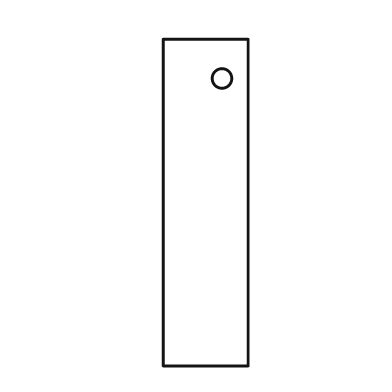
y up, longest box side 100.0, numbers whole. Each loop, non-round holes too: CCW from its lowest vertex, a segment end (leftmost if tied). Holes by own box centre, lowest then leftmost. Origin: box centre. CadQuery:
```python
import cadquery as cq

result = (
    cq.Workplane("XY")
    .moveTo(-13.0, -50.0)
    .lineTo(13.0, -50.0)
    .lineTo(13.0, 50.0)
    .lineTo(-13.0, 50.0)
    .close()
    .moveTo(5.0, 38.0)
    .circle(3.0)
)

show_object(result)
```